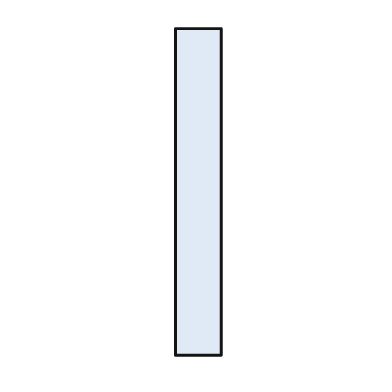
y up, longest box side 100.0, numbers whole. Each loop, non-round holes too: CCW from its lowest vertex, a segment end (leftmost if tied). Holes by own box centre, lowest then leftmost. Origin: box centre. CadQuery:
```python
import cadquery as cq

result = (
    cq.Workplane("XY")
    .moveTo(-7.0, -50.0)
    .lineTo(7.0, -50.0)
    .lineTo(7.0, 50.0)
    .lineTo(-7.0, 50.0)
    .close()
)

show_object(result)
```